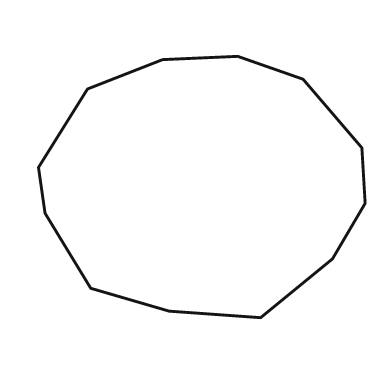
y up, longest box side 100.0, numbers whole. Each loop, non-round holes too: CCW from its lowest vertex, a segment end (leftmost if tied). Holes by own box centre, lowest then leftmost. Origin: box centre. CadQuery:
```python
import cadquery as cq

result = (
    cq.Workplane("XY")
    .moveTo(18.0, -40.0)
    .lineTo(40.0, -22.0)
    .lineTo(50.0, -5.0)
    .lineTo(49.0, 12.0)
    .lineTo(31.0, 33.0)
    .lineTo(11.0, 40.0)
    .lineTo(-12.0, 39.0)
    .lineTo(-35.0, 30.0)
    .lineTo(-50.0, 6.0)
    .lineTo(-48.0, -8.0)
    .lineTo(-34.0, -31.0)
    .lineTo(-10.0, -38.0)
    .close()
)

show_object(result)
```